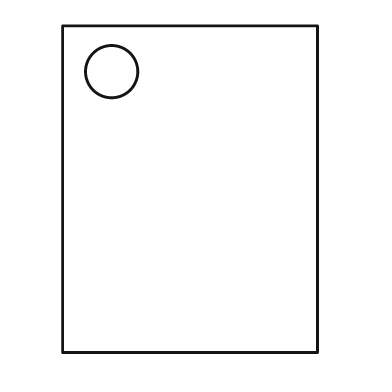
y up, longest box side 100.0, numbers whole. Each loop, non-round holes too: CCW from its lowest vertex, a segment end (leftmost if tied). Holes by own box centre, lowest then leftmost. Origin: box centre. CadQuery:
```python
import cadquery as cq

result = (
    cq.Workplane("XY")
    .moveTo(-39.0, -50.0)
    .lineTo(39.0, -50.0)
    .lineTo(39.0, 50.0)
    .lineTo(-39.0, 50.0)
    .close()
    .moveTo(-24.0, 36.0)
    .circle(8.0)
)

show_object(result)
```